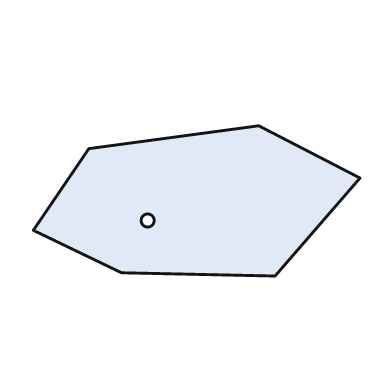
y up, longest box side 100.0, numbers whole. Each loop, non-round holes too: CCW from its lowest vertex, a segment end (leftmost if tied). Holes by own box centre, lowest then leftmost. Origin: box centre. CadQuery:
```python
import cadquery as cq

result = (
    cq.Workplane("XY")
    .moveTo(24.0, -23.0)
    .lineTo(50.0, 7.0)
    .lineTo(19.0, 23.0)
    .lineTo(-33.0, 16.0)
    .lineTo(-50.0, -9.0)
    .lineTo(-23.0, -22.0)
    .close()
    .moveTo(-15.0, -6.0)
    .circle(2.0)
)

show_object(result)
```